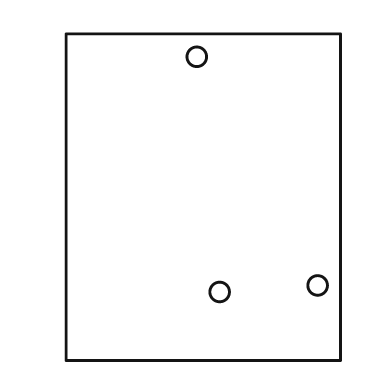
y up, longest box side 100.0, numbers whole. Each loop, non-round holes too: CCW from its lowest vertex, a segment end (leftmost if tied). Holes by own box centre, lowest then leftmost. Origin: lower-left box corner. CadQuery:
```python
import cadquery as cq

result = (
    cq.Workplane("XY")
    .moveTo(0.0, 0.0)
    .lineTo(84.0, 0.0)
    .lineTo(84.0, 100.0)
    .lineTo(0.0, 100.0)
    .close()
    .moveTo(47.0, 21.0)
    .circle(3.0)
    .moveTo(77.0, 23.0)
    .circle(3.0)
    .moveTo(40.0, 93.0)
    .circle(3.0)
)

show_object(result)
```